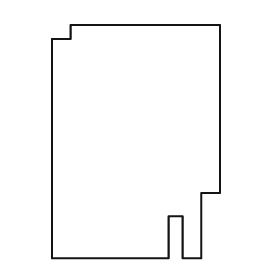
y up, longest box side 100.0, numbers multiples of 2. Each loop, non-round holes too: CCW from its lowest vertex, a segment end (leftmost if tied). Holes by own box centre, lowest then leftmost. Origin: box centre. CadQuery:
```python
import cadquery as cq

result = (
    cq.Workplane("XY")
    .moveTo(-36.0, -50.0)
    .lineTo(14.0, -50.0)
    .lineTo(14.0, -32.0)
    .lineTo(20.0, -32.0)
    .lineTo(20.0, -50.0)
    .lineTo(28.0, -50.0)
    .lineTo(28.0, -22.0)
    .lineTo(36.0, -22.0)
    .lineTo(36.0, 50.0)
    .lineTo(-28.0, 50.0)
    .lineTo(-28.0, 44.0)
    .lineTo(-36.0, 44.0)
    .close()
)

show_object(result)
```